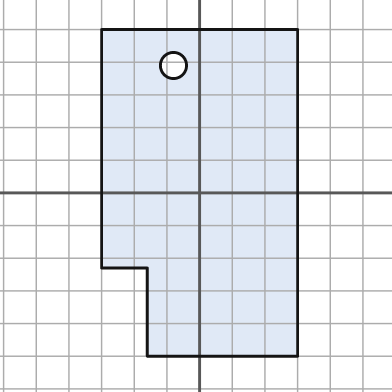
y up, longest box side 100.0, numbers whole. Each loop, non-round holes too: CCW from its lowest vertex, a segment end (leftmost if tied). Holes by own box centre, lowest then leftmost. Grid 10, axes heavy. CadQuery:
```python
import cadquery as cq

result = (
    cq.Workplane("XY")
    .moveTo(-16.0, -50.0)
    .lineTo(30.0, -50.0)
    .lineTo(30.0, 50.0)
    .lineTo(-30.0, 50.0)
    .lineTo(-30.0, -23.0)
    .lineTo(-16.0, -23.0)
    .close()
    .moveTo(-8.0, 39.0)
    .circle(4.0)
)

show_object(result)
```